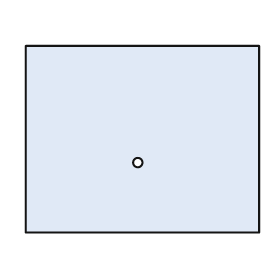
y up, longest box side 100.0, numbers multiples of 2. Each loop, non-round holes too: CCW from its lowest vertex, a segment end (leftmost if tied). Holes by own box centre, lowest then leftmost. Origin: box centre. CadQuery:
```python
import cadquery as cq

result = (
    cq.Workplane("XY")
    .moveTo(-50.0, -40.0)
    .lineTo(50.0, -40.0)
    .lineTo(50.0, 40.0)
    .lineTo(-50.0, 40.0)
    .close()
    .moveTo(-2.0, -10.0)
    .circle(2.0)
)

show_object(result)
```